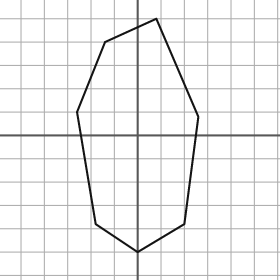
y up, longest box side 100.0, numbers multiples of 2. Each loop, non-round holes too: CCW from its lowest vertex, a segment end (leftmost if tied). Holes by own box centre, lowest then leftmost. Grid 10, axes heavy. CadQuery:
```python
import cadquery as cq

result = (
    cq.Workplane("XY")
    .moveTo(0.0, -50.0)
    .lineTo(20.0, -38.0)
    .lineTo(26.0, 8.0)
    .lineTo(8.0, 50.0)
    .lineTo(-14.0, 40.0)
    .lineTo(-26.0, 10.0)
    .lineTo(-18.0, -38.0)
    .close()
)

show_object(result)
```